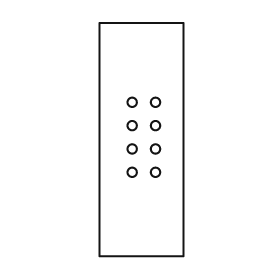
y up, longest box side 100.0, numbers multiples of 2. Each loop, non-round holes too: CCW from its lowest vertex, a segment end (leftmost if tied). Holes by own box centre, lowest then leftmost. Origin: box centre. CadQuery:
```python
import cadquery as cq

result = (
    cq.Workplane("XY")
    .moveTo(-18.0, -50.0)
    .lineTo(18.0, -50.0)
    .lineTo(18.0, 50.0)
    .lineTo(-18.0, 50.0)
    .close()
    .moveTo(-4.0, -14.0)
    .circle(2.0)
    .moveTo(6.0, -14.0)
    .circle(2.0)
    .moveTo(-4.0, -4.0)
    .circle(2.0)
    .moveTo(6.0, -4.0)
    .circle(2.0)
    .moveTo(-4.0, 6.0)
    .circle(2.0)
    .moveTo(6.0, 6.0)
    .circle(2.0)
    .moveTo(-4.0, 16.0)
    .circle(2.0)
    .moveTo(6.0, 16.0)
    .circle(2.0)
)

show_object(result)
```